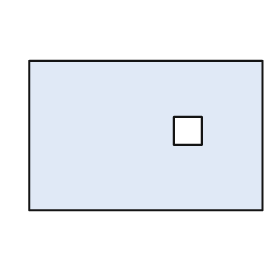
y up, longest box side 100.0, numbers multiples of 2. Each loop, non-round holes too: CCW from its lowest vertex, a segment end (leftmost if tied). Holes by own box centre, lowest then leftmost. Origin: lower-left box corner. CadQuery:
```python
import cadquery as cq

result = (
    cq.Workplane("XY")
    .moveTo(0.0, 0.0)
    .lineTo(100.0, 0.0)
    .lineTo(100.0, 64.0)
    .lineTo(0.0, 64.0)
    .close()
    .moveTo(62.0, 28.0)
    .lineTo(74.0, 28.0)
    .lineTo(74.0, 40.0)
    .lineTo(62.0, 40.0)
    .close()
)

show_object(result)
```